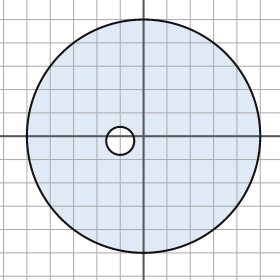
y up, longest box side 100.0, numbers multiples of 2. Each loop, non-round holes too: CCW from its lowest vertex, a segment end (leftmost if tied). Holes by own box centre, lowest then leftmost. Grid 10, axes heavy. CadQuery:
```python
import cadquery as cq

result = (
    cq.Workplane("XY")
    .moveTo(0.0, 0.0)
    .circle(50.0)
    .moveTo(-10.0, -2.0)
    .circle(6.0)
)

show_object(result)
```